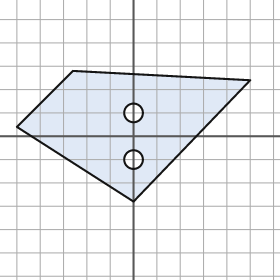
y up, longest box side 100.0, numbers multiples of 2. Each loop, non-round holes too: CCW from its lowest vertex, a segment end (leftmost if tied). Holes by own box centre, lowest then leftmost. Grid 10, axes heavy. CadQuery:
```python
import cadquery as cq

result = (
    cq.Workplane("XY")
    .moveTo(0.0, -28.0)
    .lineTo(50.0, 24.0)
    .lineTo(-26.0, 28.0)
    .lineTo(-50.0, 4.0)
    .close()
    .moveTo(0.0, -10.0)
    .circle(4.0)
    .moveTo(0.0, 10.0)
    .circle(4.0)
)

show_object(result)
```